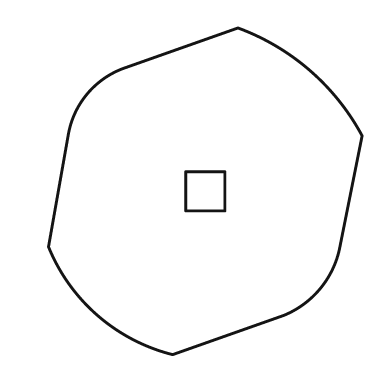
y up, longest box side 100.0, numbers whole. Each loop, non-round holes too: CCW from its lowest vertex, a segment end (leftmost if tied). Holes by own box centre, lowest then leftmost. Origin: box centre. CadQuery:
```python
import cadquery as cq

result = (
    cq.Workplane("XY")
    .moveTo(-10.0, -50.0)
    .lineTo(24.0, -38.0)
    .threePointArc((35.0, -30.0), (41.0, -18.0))
    .lineTo(48.0, 17.0)
    .threePointArc((32.0, 37.0), (10.0, 50.0))
    .lineTo(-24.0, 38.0)
    .threePointArc((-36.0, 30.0), (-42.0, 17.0))
    .lineTo(-48.0, -17.0)
    .threePointArc((-33.0, -38.0), (-10.0, -50.0))
    .close()
    .moveTo(-6.0, -6.0)
    .lineTo(6.0, -6.0)
    .lineTo(6.0, 6.0)
    .lineTo(-6.0, 6.0)
    .close()
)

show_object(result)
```